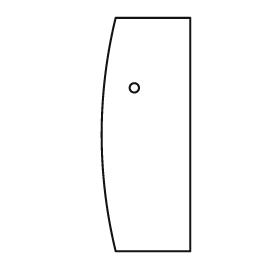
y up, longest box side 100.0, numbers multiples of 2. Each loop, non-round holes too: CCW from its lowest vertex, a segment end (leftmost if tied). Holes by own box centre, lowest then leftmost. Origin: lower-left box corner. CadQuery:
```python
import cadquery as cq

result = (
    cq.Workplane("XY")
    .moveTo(6.0, 0.0)
    .lineTo(38.0, 0.0)
    .lineTo(38.0, 100.0)
    .lineTo(6.0, 100.0)
    .threePointArc((0.0, 50.0), (6.0, 0.0))
    .close()
    .moveTo(14.0, 70.0)
    .circle(2.0)
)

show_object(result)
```